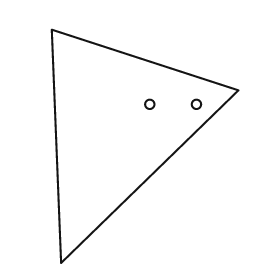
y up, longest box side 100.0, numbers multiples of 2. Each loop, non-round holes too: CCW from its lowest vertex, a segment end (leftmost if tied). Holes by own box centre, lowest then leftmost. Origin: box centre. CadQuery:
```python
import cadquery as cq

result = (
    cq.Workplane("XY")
    .moveTo(-36.0, -50.0)
    .lineTo(40.0, 24.0)
    .lineTo(-40.0, 50.0)
    .close()
    .moveTo(2.0, 18.0)
    .circle(2.0)
    .moveTo(22.0, 18.0)
    .circle(2.0)
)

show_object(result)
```